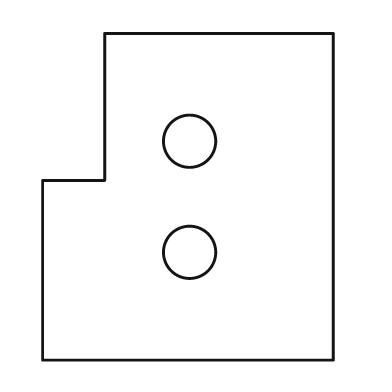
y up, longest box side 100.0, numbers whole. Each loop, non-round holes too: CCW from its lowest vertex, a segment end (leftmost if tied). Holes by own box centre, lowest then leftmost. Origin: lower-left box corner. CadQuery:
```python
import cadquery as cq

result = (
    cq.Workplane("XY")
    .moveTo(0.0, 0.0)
    .lineTo(89.0, 0.0)
    .lineTo(89.0, 100.0)
    .lineTo(19.0, 100.0)
    .lineTo(19.0, 55.0)
    .lineTo(0.0, 55.0)
    .close()
    .moveTo(45.0, 33.0)
    .circle(8.0)
    .moveTo(45.0, 67.0)
    .circle(8.0)
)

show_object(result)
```